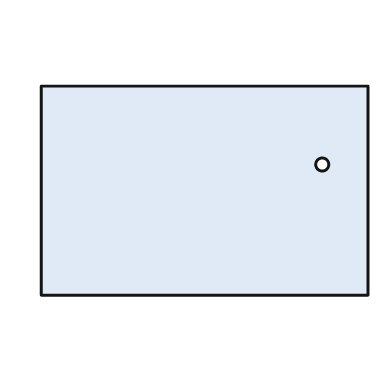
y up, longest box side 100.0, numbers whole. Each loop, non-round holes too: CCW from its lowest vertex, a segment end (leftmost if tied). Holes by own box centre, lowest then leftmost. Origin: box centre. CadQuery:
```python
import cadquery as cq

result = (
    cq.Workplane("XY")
    .moveTo(-50.0, -32.0)
    .lineTo(50.0, -32.0)
    .lineTo(50.0, 32.0)
    .lineTo(-50.0, 32.0)
    .close()
    .moveTo(36.0, 8.0)
    .circle(2.0)
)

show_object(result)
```